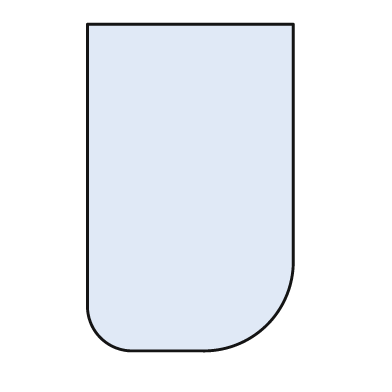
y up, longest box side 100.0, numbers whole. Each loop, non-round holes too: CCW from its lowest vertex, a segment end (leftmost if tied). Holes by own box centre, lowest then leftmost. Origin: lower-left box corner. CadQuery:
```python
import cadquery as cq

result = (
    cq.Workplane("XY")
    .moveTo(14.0, 0.0)
    .lineTo(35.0, 0.0)
    .threePointArc((55.0, 8.0), (63.0, 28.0))
    .lineTo(63.0, 100.0)
    .lineTo(0.0, 100.0)
    .lineTo(0.0, 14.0)
    .threePointArc((4.0, 4.0), (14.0, 0.0))
    .close()
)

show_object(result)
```